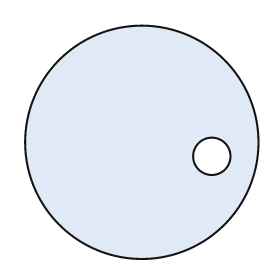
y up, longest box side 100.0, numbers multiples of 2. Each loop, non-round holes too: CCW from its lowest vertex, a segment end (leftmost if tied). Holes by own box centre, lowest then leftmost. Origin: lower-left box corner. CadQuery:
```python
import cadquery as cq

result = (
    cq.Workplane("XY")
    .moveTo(50.0, 50.0)
    .circle(50.0)
    .moveTo(80.0, 44.0)
    .circle(8.0)
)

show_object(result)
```